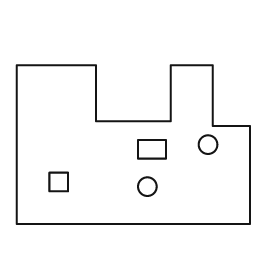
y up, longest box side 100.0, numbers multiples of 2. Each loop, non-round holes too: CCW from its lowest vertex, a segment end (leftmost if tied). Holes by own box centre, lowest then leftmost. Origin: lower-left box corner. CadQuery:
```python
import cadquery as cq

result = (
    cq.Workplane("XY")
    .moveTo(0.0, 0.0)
    .lineTo(100.0, 0.0)
    .lineTo(100.0, 42.0)
    .lineTo(84.0, 42.0)
    .lineTo(84.0, 68.0)
    .lineTo(66.0, 68.0)
    .lineTo(66.0, 44.0)
    .lineTo(34.0, 44.0)
    .lineTo(34.0, 68.0)
    .lineTo(0.0, 68.0)
    .close()
    .moveTo(56.0, 16.0)
    .circle(4.0)
    .moveTo(14.0, 14.0)
    .lineTo(22.0, 14.0)
    .lineTo(22.0, 22.0)
    .lineTo(14.0, 22.0)
    .close()
    .moveTo(52.0, 28.0)
    .lineTo(64.0, 28.0)
    .lineTo(64.0, 36.0)
    .lineTo(52.0, 36.0)
    .close()
    .moveTo(82.0, 34.0)
    .circle(4.0)
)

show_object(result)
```